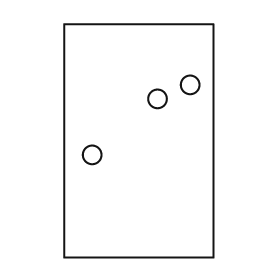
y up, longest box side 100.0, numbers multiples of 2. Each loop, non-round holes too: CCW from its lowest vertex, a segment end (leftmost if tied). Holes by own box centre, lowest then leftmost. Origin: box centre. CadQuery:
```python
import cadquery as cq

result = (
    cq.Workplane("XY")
    .moveTo(-32.0, -50.0)
    .lineTo(32.0, -50.0)
    .lineTo(32.0, 50.0)
    .lineTo(-32.0, 50.0)
    .close()
    .moveTo(-20.0, -6.0)
    .circle(4.0)
    .moveTo(8.0, 18.0)
    .circle(4.0)
    .moveTo(22.0, 24.0)
    .circle(4.0)
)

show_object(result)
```